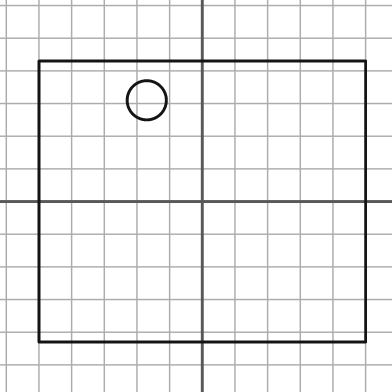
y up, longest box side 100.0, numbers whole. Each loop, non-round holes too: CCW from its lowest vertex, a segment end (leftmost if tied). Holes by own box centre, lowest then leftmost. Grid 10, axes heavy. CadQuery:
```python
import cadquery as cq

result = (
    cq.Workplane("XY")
    .moveTo(-50.0, -43.0)
    .lineTo(50.0, -43.0)
    .lineTo(50.0, 43.0)
    .lineTo(-50.0, 43.0)
    .close()
    .moveTo(-17.0, 31.0)
    .circle(6.0)
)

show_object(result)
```